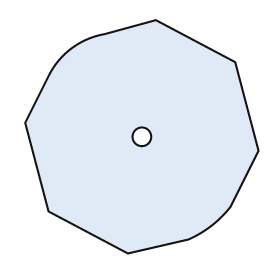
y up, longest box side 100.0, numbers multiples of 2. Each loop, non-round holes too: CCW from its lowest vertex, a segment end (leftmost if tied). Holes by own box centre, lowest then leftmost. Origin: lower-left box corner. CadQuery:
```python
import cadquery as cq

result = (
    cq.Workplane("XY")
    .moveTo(44.0, 0.0)
    .lineTo(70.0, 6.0)
    .threePointArc((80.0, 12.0), (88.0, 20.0))
    .lineTo(100.0, 44.0)
    .lineTo(90.0, 82.0)
    .lineTo(56.0, 100.0)
    .lineTo(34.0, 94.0)
    .threePointArc((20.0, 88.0), (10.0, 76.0))
    .lineTo(0.0, 56.0)
    .lineTo(10.0, 18.0)
    .close()
    .moveTo(50.0, 50.0)
    .circle(4.0)
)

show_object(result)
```